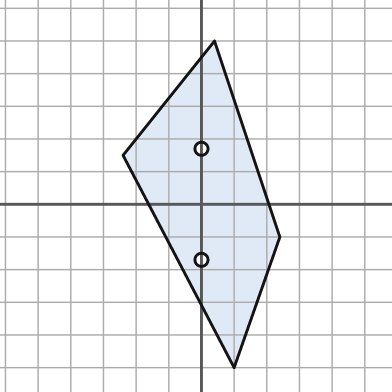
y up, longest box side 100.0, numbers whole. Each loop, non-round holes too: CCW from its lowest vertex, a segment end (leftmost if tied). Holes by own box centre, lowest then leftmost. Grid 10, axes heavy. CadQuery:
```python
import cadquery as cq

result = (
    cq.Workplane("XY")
    .moveTo(10.0, -50.0)
    .lineTo(24.0, -10.0)
    .lineTo(4.0, 50.0)
    .lineTo(-24.0, 15.0)
    .close()
    .moveTo(0.0, -17.0)
    .circle(2.0)
    .moveTo(0.0, 17.0)
    .circle(2.0)
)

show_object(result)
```